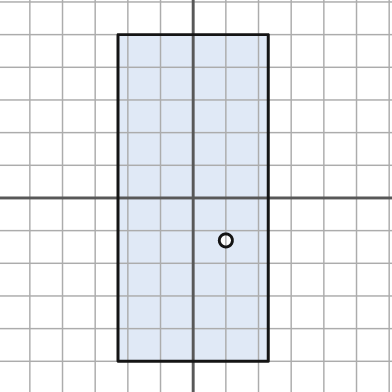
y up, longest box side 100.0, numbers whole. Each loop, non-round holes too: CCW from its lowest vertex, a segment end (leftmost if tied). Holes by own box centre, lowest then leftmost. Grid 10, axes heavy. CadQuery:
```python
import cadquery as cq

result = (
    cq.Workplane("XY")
    .moveTo(-23.0, -50.0)
    .lineTo(23.0, -50.0)
    .lineTo(23.0, 50.0)
    .lineTo(-23.0, 50.0)
    .close()
    .moveTo(10.0, -13.0)
    .circle(2.0)
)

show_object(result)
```